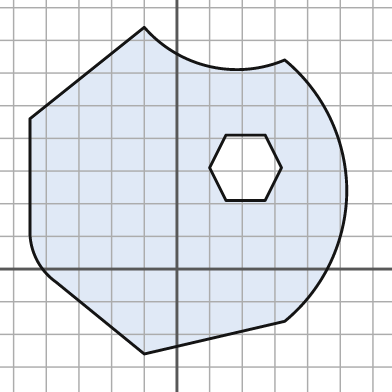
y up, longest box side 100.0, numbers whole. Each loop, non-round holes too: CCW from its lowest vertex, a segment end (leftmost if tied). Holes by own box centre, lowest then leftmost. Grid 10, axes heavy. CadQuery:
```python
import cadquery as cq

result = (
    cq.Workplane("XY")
    .moveTo(-10.0, -26.0)
    .lineTo(33.0, -16.0)
    .threePointArc((47.0, 2.0), (52.0, 24.0))
    .threePointArc((47.0, 46.0), (33.0, 64.0))
    .threePointArc((10.0, 62.0), (-10.0, 74.0))
    .lineTo(-45.0, 46.0)
    .lineTo(-45.0, 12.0)
    .threePointArc((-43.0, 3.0), (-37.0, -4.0))
    .close()
    .moveTo(15.0, 21.0)
    .lineTo(27.0, 21.0)
    .lineTo(32.0, 31.0)
    .lineTo(27.0, 41.0)
    .lineTo(15.0, 41.0)
    .lineTo(10.0, 31.0)
    .close()
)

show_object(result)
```